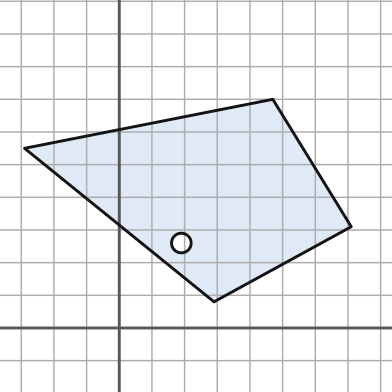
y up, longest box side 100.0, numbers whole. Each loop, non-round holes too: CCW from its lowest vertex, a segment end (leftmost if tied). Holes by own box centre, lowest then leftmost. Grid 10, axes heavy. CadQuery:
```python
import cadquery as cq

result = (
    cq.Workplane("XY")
    .moveTo(29.0, 8.0)
    .lineTo(71.0, 31.0)
    .lineTo(47.0, 70.0)
    .lineTo(-29.0, 55.0)
    .close()
    .moveTo(19.0, 26.0)
    .circle(3.0)
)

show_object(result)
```